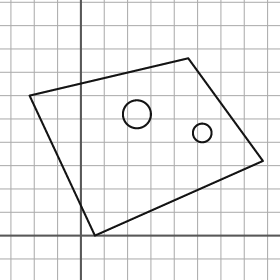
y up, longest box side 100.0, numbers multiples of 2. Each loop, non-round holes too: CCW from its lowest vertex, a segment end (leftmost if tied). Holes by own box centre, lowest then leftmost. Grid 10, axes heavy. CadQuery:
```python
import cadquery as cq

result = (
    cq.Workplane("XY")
    .moveTo(6.0, 0.0)
    .lineTo(78.0, 32.0)
    .lineTo(46.0, 76.0)
    .lineTo(-22.0, 60.0)
    .close()
    .moveTo(52.0, 44.0)
    .circle(4.0)
    .moveTo(24.0, 52.0)
    .circle(6.0)
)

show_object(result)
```